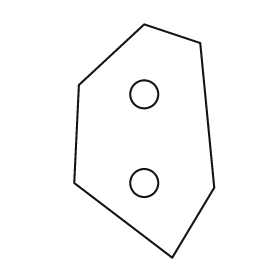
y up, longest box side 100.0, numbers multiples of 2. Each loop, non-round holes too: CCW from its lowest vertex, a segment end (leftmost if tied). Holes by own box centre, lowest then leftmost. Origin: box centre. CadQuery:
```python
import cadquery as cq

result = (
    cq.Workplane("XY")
    .moveTo(12.0, -50.0)
    .lineTo(30.0, -20.0)
    .lineTo(24.0, 42.0)
    .lineTo(0.0, 50.0)
    .lineTo(-28.0, 24.0)
    .lineTo(-30.0, -18.0)
    .close()
    .moveTo(0.0, -18.0)
    .circle(6.0)
    .moveTo(0.0, 20.0)
    .circle(6.0)
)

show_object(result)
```